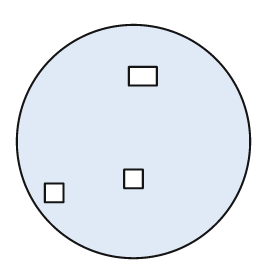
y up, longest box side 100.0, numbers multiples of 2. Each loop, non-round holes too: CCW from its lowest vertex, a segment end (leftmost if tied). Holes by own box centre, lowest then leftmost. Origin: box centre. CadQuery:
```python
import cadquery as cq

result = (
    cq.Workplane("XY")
    .moveTo(0.0, 0.0)
    .circle(50.0)
    .moveTo(-38.0, -26.0)
    .lineTo(-30.0, -26.0)
    .lineTo(-30.0, -18.0)
    .lineTo(-38.0, -18.0)
    .close()
    .moveTo(-4.0, -20.0)
    .lineTo(4.0, -20.0)
    .lineTo(4.0, -12.0)
    .lineTo(-4.0, -12.0)
    .close()
    .moveTo(-2.0, 24.0)
    .lineTo(10.0, 24.0)
    .lineTo(10.0, 32.0)
    .lineTo(-2.0, 32.0)
    .close()
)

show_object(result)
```